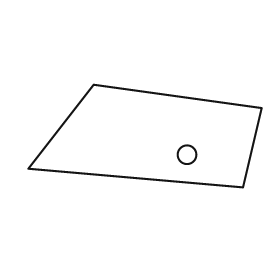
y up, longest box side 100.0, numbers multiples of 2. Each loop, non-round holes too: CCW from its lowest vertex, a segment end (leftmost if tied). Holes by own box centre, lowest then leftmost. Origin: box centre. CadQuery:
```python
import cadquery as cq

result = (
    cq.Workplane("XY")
    .moveTo(42.0, -22.0)
    .lineTo(50.0, 12.0)
    .lineTo(-22.0, 22.0)
    .lineTo(-50.0, -14.0)
    .close()
    .moveTo(18.0, -8.0)
    .circle(4.0)
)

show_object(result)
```